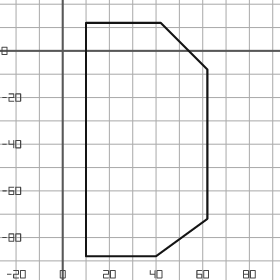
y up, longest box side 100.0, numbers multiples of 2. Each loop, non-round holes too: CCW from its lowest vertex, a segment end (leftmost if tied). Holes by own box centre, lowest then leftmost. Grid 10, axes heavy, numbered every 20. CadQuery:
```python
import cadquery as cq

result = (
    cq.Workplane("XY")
    .moveTo(10.0, -88.0)
    .lineTo(40.0, -88.0)
    .lineTo(62.0, -72.0)
    .lineTo(62.0, -8.0)
    .lineTo(42.0, 12.0)
    .lineTo(10.0, 12.0)
    .close()
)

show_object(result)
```